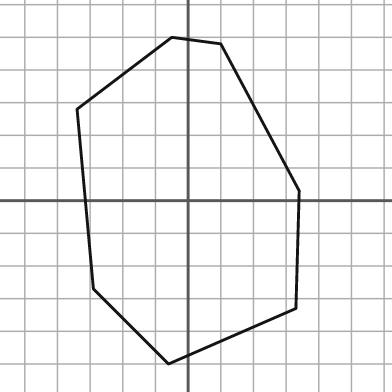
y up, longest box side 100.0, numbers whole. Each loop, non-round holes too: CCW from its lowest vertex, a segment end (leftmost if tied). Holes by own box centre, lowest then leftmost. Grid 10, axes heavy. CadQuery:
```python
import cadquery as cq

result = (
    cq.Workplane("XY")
    .moveTo(-6.0, -50.0)
    .lineTo(33.0, -33.0)
    .lineTo(34.0, 3.0)
    .lineTo(10.0, 48.0)
    .lineTo(-5.0, 50.0)
    .lineTo(-34.0, 28.0)
    .lineTo(-29.0, -27.0)
    .close()
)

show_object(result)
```